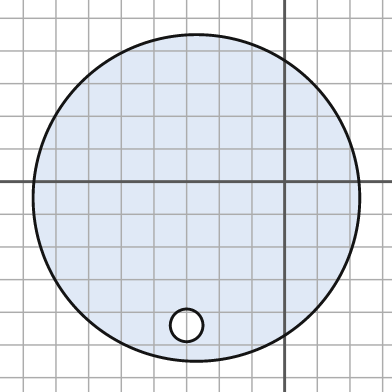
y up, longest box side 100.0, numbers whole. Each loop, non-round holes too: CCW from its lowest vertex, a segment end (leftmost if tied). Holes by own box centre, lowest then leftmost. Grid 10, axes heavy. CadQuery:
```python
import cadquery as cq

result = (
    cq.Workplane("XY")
    .moveTo(-27.0, -5.0)
    .circle(50.0)
    .moveTo(-30.0, -44.0)
    .circle(5.0)
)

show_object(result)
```